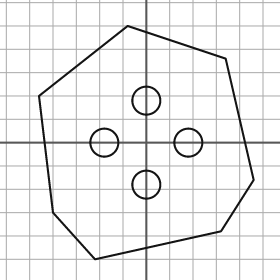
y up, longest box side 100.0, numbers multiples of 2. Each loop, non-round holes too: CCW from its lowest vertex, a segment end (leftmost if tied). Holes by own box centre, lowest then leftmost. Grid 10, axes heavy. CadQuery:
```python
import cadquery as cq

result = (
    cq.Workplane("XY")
    .moveTo(-22.0, -50.0)
    .lineTo(32.0, -38.0)
    .lineTo(46.0, -16.0)
    .lineTo(34.0, 36.0)
    .lineTo(-8.0, 50.0)
    .lineTo(-46.0, 20.0)
    .lineTo(-40.0, -30.0)
    .close()
    .moveTo(0.0, -18.0)
    .circle(6.0)
    .moveTo(-18.0, 0.0)
    .circle(6.0)
    .moveTo(18.0, 0.0)
    .circle(6.0)
    .moveTo(0.0, 18.0)
    .circle(6.0)
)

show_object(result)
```